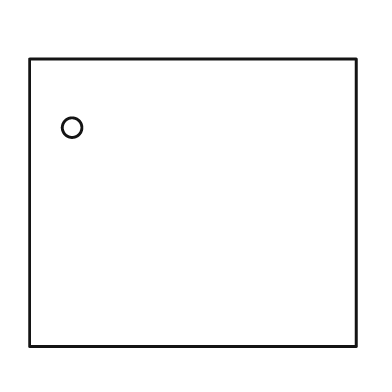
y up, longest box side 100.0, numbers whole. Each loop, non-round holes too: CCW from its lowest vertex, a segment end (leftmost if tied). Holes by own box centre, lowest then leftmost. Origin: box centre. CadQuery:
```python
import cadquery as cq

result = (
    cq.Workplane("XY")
    .moveTo(-50.0, -44.0)
    .lineTo(50.0, -44.0)
    .lineTo(50.0, 44.0)
    .lineTo(-50.0, 44.0)
    .close()
    .moveTo(-37.0, 23.0)
    .circle(3.0)
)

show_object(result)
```